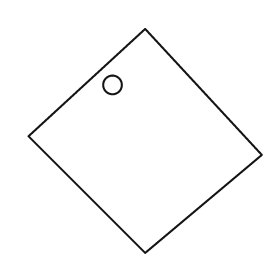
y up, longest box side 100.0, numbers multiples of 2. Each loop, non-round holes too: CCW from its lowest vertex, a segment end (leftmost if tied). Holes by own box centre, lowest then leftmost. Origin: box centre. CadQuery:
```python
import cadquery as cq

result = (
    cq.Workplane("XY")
    .moveTo(0.0, -48.0)
    .lineTo(50.0, -6.0)
    .lineTo(0.0, 48.0)
    .lineTo(-50.0, 2.0)
    .close()
    .moveTo(-14.0, 24.0)
    .circle(4.0)
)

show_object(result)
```